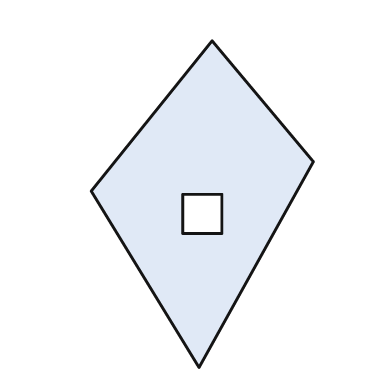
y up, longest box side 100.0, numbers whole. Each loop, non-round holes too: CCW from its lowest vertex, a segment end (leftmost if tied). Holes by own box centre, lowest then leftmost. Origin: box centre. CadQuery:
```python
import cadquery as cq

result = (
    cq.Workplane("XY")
    .moveTo(-1.0, -50.0)
    .lineTo(34.0, 13.0)
    .lineTo(3.0, 50.0)
    .lineTo(-34.0, 4.0)
    .close()
    .moveTo(-6.0, -9.0)
    .lineTo(6.0, -9.0)
    .lineTo(6.0, 3.0)
    .lineTo(-6.0, 3.0)
    .close()
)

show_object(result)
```